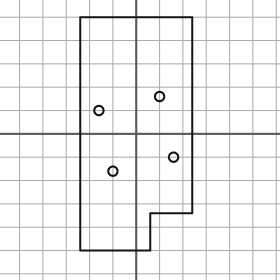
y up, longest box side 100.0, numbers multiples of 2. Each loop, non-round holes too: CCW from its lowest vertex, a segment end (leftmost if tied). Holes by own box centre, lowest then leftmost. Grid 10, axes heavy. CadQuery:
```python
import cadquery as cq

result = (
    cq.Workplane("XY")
    .moveTo(-24.0, -50.0)
    .lineTo(6.0, -50.0)
    .lineTo(6.0, -34.0)
    .lineTo(24.0, -34.0)
    .lineTo(24.0, 50.0)
    .lineTo(-24.0, 50.0)
    .close()
    .moveTo(-10.0, -16.0)
    .circle(2.0)
    .moveTo(16.0, -10.0)
    .circle(2.0)
    .moveTo(-16.0, 10.0)
    .circle(2.0)
    .moveTo(10.0, 16.0)
    .circle(2.0)
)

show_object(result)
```